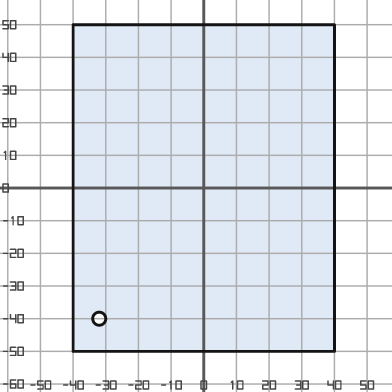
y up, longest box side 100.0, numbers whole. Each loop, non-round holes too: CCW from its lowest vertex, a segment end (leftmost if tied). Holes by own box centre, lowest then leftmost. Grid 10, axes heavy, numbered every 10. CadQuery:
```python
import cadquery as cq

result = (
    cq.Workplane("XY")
    .moveTo(-40.0, -50.0)
    .lineTo(40.0, -50.0)
    .lineTo(40.0, 50.0)
    .lineTo(-40.0, 50.0)
    .close()
    .moveTo(-32.0, -40.0)
    .circle(2.0)
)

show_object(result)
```